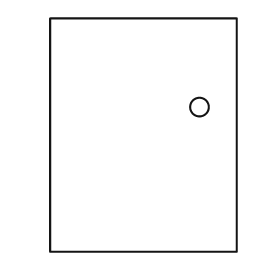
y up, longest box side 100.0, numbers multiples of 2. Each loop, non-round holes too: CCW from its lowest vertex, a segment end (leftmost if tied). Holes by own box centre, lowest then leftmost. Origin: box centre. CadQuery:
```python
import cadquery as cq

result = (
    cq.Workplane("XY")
    .moveTo(-40.0, -50.0)
    .lineTo(40.0, -50.0)
    .lineTo(40.0, 50.0)
    .lineTo(-40.0, 50.0)
    .close()
    .moveTo(24.0, 12.0)
    .circle(4.0)
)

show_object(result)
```